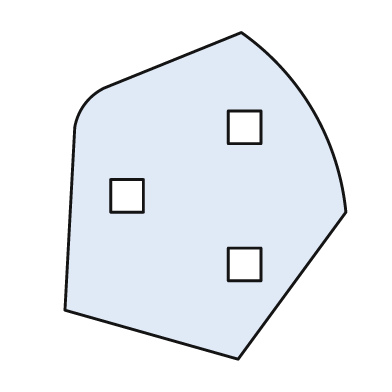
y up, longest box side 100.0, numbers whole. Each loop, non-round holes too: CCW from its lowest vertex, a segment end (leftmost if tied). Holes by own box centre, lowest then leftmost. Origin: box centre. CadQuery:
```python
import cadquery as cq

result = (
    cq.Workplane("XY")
    .moveTo(10.0, -50.0)
    .lineTo(43.0, -5.0)
    .threePointArc((33.0, 26.0), (11.0, 50.0))
    .lineTo(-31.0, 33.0)
    .threePointArc((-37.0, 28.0), (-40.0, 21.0))
    .lineTo(-43.0, -35.0)
    .close()
    .moveTo(7.0, -26.0)
    .lineTo(17.0, -26.0)
    .lineTo(17.0, -16.0)
    .lineTo(7.0, -16.0)
    .close()
    .moveTo(-29.0, -5.0)
    .lineTo(-19.0, -5.0)
    .lineTo(-19.0, 5.0)
    .lineTo(-29.0, 5.0)
    .close()
    .moveTo(7.0, 16.0)
    .lineTo(17.0, 16.0)
    .lineTo(17.0, 26.0)
    .lineTo(7.0, 26.0)
    .close()
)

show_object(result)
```